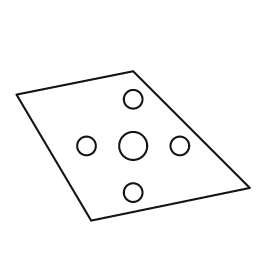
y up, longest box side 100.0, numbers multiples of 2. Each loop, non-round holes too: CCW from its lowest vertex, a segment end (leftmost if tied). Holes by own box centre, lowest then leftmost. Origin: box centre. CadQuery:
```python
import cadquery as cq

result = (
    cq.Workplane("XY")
    .moveTo(-18.0, -32.0)
    .lineTo(50.0, -18.0)
    .lineTo(0.0, 32.0)
    .lineTo(-50.0, 22.0)
    .close()
    .moveTo(0.0, -20.0)
    .circle(4.0)
    .moveTo(-20.0, 0.0)
    .circle(4.0)
    .moveTo(0.0, 0.0)
    .circle(6.0)
    .moveTo(20.0, 0.0)
    .circle(4.0)
    .moveTo(0.0, 20.0)
    .circle(4.0)
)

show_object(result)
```